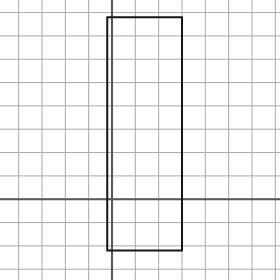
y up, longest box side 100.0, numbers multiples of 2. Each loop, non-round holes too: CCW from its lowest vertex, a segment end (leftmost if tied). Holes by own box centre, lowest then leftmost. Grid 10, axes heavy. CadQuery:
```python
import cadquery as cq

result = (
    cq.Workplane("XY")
    .moveTo(-2.0, -22.0)
    .lineTo(30.0, -22.0)
    .lineTo(30.0, 78.0)
    .lineTo(-2.0, 78.0)
    .close()
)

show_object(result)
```